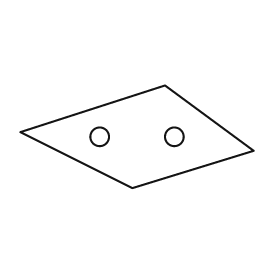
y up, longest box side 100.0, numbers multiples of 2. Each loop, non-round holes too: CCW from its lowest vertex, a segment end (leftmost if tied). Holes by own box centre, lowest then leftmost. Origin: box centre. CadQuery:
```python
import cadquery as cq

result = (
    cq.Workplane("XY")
    .moveTo(-2.0, -22.0)
    .lineTo(50.0, -6.0)
    .lineTo(12.0, 22.0)
    .lineTo(-50.0, 2.0)
    .close()
    .moveTo(-16.0, 0.0)
    .circle(4.0)
    .moveTo(16.0, 0.0)
    .circle(4.0)
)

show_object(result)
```